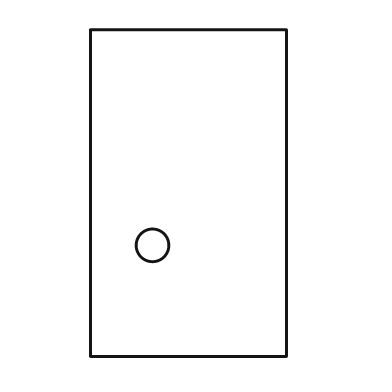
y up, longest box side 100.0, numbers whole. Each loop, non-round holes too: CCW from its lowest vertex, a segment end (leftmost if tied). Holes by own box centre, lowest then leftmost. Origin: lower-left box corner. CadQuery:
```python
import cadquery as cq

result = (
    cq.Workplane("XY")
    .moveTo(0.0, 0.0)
    .lineTo(60.0, 0.0)
    .lineTo(60.0, 100.0)
    .lineTo(0.0, 100.0)
    .close()
    .moveTo(19.0, 34.0)
    .circle(5.0)
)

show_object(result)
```